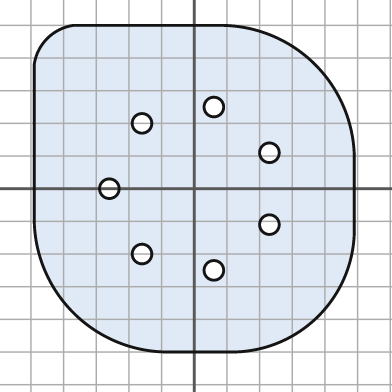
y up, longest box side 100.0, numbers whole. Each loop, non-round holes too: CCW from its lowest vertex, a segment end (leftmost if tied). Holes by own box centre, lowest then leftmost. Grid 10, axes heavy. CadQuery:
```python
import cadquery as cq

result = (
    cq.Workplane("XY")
    .moveTo(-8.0, -50.0)
    .lineTo(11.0, -50.0)
    .threePointArc((38.0, -39.0), (49.0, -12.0))
    .lineTo(49.0, 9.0)
    .threePointArc((37.0, 38.0), (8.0, 50.0))
    .lineTo(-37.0, 50.0)
    .threePointArc((-45.0, 46.0), (-49.0, 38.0))
    .lineTo(-49.0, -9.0)
    .threePointArc((-37.0, -38.0), (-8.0, -50.0))
    .close()
    .moveTo(6.0, -25.0)
    .circle(3.0)
    .moveTo(-16.0, -20.0)
    .circle(3.0)
    .moveTo(23.0, -11.0)
    .circle(3.0)
    .moveTo(-26.0, 0.0)
    .circle(3.0)
    .moveTo(23.0, 11.0)
    .circle(3.0)
    .moveTo(-16.0, 20.0)
    .circle(3.0)
    .moveTo(6.0, 25.0)
    .circle(3.0)
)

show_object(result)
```